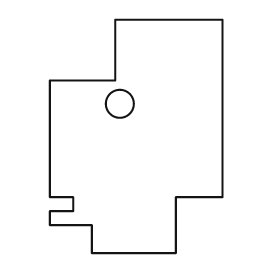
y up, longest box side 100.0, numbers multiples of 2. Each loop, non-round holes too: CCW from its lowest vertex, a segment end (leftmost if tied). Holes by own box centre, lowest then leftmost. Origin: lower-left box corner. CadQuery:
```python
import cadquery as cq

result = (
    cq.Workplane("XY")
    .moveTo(18.0, 0.0)
    .lineTo(54.0, 0.0)
    .lineTo(54.0, 24.0)
    .lineTo(74.0, 24.0)
    .lineTo(74.0, 100.0)
    .lineTo(28.0, 100.0)
    .lineTo(28.0, 74.0)
    .lineTo(0.0, 74.0)
    .lineTo(0.0, 24.0)
    .lineTo(10.0, 24.0)
    .lineTo(10.0, 18.0)
    .lineTo(0.0, 18.0)
    .lineTo(0.0, 12.0)
    .lineTo(18.0, 12.0)
    .close()
    .moveTo(30.0, 64.0)
    .circle(6.0)
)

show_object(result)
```